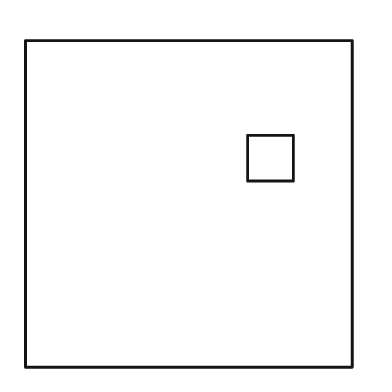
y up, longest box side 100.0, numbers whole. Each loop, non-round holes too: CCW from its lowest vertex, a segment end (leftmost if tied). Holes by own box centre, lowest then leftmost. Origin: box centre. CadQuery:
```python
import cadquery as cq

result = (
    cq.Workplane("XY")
    .moveTo(-50.0, -50.0)
    .lineTo(50.0, -50.0)
    .lineTo(50.0, 50.0)
    .lineTo(-50.0, 50.0)
    .close()
    .moveTo(18.0, 7.0)
    .lineTo(32.0, 7.0)
    .lineTo(32.0, 21.0)
    .lineTo(18.0, 21.0)
    .close()
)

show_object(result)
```